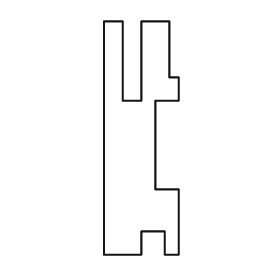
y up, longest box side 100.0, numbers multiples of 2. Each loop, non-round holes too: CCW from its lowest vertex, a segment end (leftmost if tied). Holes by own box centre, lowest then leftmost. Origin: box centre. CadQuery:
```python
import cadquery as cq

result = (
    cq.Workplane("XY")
    .moveTo(-16.0, -50.0)
    .lineTo(0.0, -50.0)
    .lineTo(0.0, -40.0)
    .lineTo(10.0, -40.0)
    .lineTo(10.0, -50.0)
    .lineTo(16.0, -50.0)
    .lineTo(16.0, -22.0)
    .lineTo(6.0, -22.0)
    .lineTo(6.0, 16.0)
    .lineTo(16.0, 16.0)
    .lineTo(16.0, 26.0)
    .lineTo(12.0, 26.0)
    .lineTo(12.0, 50.0)
    .lineTo(0.0, 50.0)
    .lineTo(0.0, 16.0)
    .lineTo(-8.0, 16.0)
    .lineTo(-8.0, 50.0)
    .lineTo(-16.0, 50.0)
    .close()
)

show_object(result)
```